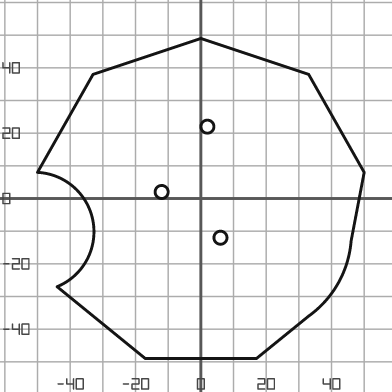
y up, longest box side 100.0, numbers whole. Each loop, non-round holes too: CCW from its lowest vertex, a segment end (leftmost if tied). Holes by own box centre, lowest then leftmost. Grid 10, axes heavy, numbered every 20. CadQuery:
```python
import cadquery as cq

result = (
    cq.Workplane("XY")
    .moveTo(-17.0, -49.0)
    .lineTo(17.0, -49.0)
    .lineTo(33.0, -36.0)
    .threePointArc((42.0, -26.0), (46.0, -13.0))
    .lineTo(50.0, 8.0)
    .lineTo(33.0, 38.0)
    .lineTo(0.0, 49.0)
    .lineTo(-33.0, 38.0)
    .lineTo(-50.0, 8.0)
    .threePointArc((-33.0, -7.0), (-44.0, -27.0))
    .close()
    .moveTo(6.0, -12.0)
    .circle(2.0)
    .moveTo(-12.0, 2.0)
    .circle(2.0)
    .moveTo(2.0, 22.0)
    .circle(2.0)
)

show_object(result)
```